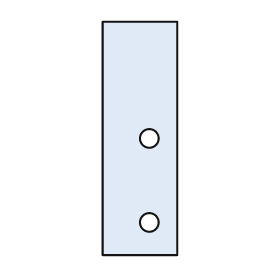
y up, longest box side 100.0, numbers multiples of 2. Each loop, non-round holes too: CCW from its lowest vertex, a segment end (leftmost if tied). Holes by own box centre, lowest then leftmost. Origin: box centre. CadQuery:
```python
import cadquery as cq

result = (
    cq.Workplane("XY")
    .moveTo(-16.0, -50.0)
    .lineTo(16.0, -50.0)
    .lineTo(16.0, 50.0)
    .lineTo(-16.0, 50.0)
    .close()
    .moveTo(4.0, -36.0)
    .circle(4.0)
    .moveTo(4.0, 0.0)
    .circle(4.0)
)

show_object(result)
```